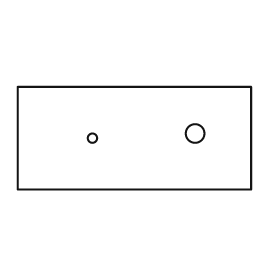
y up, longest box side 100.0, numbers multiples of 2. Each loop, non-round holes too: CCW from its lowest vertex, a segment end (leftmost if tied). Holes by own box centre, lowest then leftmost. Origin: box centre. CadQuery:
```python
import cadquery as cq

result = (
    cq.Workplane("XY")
    .moveTo(-50.0, -22.0)
    .lineTo(50.0, -22.0)
    .lineTo(50.0, 22.0)
    .lineTo(-50.0, 22.0)
    .close()
    .moveTo(-18.0, 0.0)
    .circle(2.0)
    .moveTo(26.0, 2.0)
    .circle(4.0)
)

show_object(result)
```